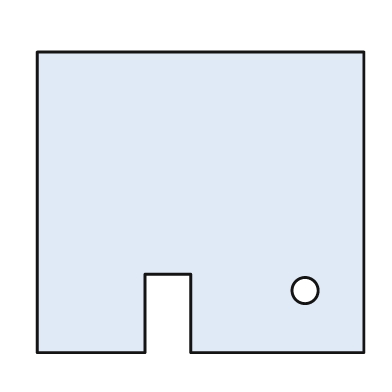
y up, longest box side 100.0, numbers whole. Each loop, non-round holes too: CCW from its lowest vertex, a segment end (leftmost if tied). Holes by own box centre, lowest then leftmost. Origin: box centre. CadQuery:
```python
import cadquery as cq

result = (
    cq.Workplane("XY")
    .moveTo(-50.0, -46.0)
    .lineTo(-17.0, -46.0)
    .lineTo(-17.0, -22.0)
    .lineTo(-3.0, -22.0)
    .lineTo(-3.0, -46.0)
    .lineTo(50.0, -46.0)
    .lineTo(50.0, 46.0)
    .lineTo(-50.0, 46.0)
    .close()
    .moveTo(32.0, -27.0)
    .circle(4.0)
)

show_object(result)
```